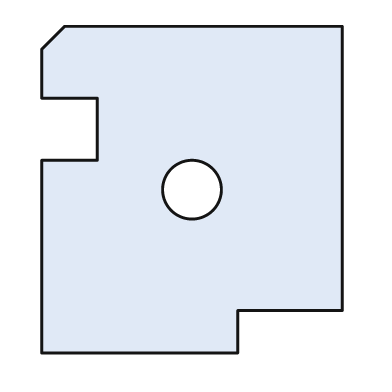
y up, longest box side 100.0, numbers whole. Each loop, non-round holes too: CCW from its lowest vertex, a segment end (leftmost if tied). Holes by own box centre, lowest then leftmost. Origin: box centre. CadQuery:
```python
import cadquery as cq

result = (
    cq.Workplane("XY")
    .moveTo(-46.0, -50.0)
    .lineTo(14.0, -50.0)
    .lineTo(14.0, -37.0)
    .lineTo(46.0, -37.0)
    .lineTo(46.0, 50.0)
    .lineTo(-39.0, 50.0)
    .lineTo(-46.0, 43.0)
    .lineTo(-46.0, 28.0)
    .lineTo(-29.0, 28.0)
    .lineTo(-29.0, 9.0)
    .lineTo(-46.0, 9.0)
    .close()
    .moveTo(0.0, 0.0)
    .circle(9.0)
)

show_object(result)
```